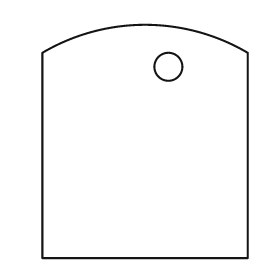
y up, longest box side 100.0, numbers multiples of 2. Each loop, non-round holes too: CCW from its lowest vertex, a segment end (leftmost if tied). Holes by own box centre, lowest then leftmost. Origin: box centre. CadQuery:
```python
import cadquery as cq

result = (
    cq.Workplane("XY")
    .moveTo(-44.0, -50.0)
    .lineTo(44.0, -50.0)
    .lineTo(44.0, 38.0)
    .threePointArc((0.0, 50.0), (-44.0, 38.0))
    .close()
    .moveTo(10.0, 32.0)
    .circle(6.0)
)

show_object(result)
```